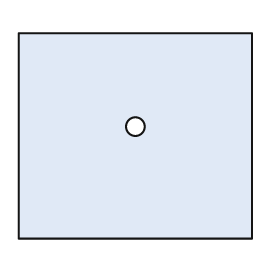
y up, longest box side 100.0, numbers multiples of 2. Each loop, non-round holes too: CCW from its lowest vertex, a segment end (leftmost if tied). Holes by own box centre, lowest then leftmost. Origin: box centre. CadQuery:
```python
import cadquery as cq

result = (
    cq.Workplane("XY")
    .moveTo(-50.0, -44.0)
    .lineTo(50.0, -44.0)
    .lineTo(50.0, 44.0)
    .lineTo(-50.0, 44.0)
    .close()
    .moveTo(0.0, 4.0)
    .circle(4.0)
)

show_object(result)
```